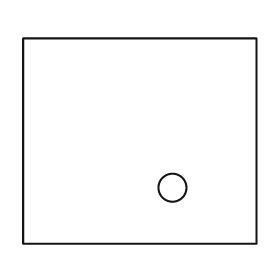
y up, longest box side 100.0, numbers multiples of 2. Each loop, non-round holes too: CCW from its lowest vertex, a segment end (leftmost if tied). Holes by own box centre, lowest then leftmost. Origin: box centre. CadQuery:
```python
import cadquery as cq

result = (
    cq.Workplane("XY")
    .moveTo(-50.0, -44.0)
    .lineTo(50.0, -44.0)
    .lineTo(50.0, 44.0)
    .lineTo(-50.0, 44.0)
    .close()
    .moveTo(14.0, -20.0)
    .circle(6.0)
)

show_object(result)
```